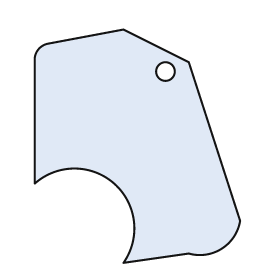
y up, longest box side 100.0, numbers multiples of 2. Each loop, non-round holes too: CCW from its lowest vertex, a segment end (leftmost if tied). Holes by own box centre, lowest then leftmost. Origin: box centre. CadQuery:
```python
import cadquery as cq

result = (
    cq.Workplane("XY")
    .moveTo(-6.0, -50.0)
    .lineTo(22.0, -46.0)
    .threePointArc((36.0, -44.0), (44.0, -32.0))
    .lineTo(22.0, 36.0)
    .lineTo(-6.0, 50.0)
    .lineTo(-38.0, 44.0)
    .threePointArc((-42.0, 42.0), (-44.0, 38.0))
    .lineTo(-44.0, -16.0)
    .threePointArc((-10.0, -16.0), (-6.0, -50.0))
    .close()
    .moveTo(12.0, 32.0)
    .circle(4.0)
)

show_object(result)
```